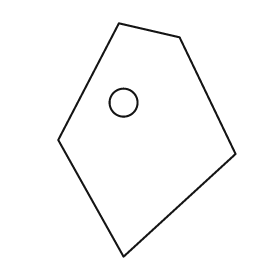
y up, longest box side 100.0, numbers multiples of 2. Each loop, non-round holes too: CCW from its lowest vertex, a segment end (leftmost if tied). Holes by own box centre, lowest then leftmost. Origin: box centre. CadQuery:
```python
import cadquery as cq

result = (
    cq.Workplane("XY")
    .moveTo(-10.0, -50.0)
    .lineTo(38.0, -6.0)
    .lineTo(14.0, 44.0)
    .lineTo(-12.0, 50.0)
    .lineTo(-38.0, 0.0)
    .close()
    .moveTo(-10.0, 16.0)
    .circle(6.0)
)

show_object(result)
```